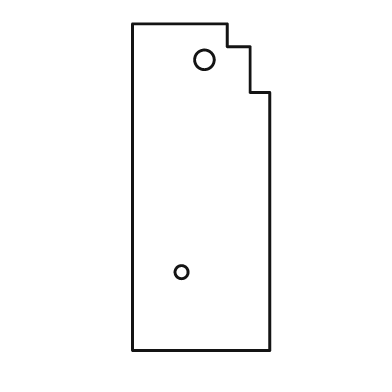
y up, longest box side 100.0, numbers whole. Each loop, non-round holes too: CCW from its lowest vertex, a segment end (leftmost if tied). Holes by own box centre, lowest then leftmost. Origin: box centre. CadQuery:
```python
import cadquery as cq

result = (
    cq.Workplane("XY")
    .moveTo(-21.0, -50.0)
    .lineTo(21.0, -50.0)
    .lineTo(21.0, 29.0)
    .lineTo(15.0, 29.0)
    .lineTo(15.0, 43.0)
    .lineTo(8.0, 43.0)
    .lineTo(8.0, 50.0)
    .lineTo(-21.0, 50.0)
    .close()
    .moveTo(-6.0, -26.0)
    .circle(2.0)
    .moveTo(1.0, 39.0)
    .circle(3.0)
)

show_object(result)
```